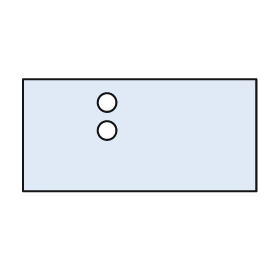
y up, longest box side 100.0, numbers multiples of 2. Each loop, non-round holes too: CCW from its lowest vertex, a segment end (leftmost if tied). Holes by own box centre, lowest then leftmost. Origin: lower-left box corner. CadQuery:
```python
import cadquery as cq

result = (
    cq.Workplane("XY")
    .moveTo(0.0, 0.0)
    .lineTo(100.0, 0.0)
    .lineTo(100.0, 48.0)
    .lineTo(0.0, 48.0)
    .close()
    .moveTo(36.0, 26.0)
    .circle(4.0)
    .moveTo(36.0, 38.0)
    .circle(4.0)
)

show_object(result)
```